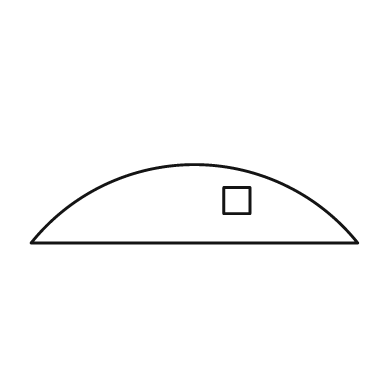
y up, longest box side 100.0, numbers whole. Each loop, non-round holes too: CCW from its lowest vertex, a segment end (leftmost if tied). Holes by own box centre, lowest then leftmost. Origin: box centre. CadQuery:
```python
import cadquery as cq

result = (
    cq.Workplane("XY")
    .moveTo(-50.0, -12.0)
    .lineTo(50.0, -12.0)
    .threePointArc((0.0, 12.0), (-50.0, -12.0))
    .close()
    .moveTo(9.0, -3.0)
    .lineTo(17.0, -3.0)
    .lineTo(17.0, 5.0)
    .lineTo(9.0, 5.0)
    .close()
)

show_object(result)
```